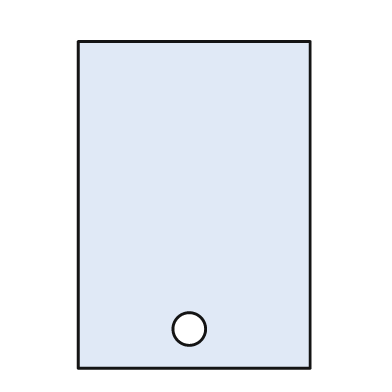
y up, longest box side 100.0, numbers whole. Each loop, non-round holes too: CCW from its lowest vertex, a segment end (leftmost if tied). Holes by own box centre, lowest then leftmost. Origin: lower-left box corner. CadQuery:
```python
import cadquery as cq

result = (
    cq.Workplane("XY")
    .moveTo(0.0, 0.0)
    .lineTo(71.0, 0.0)
    .lineTo(71.0, 100.0)
    .lineTo(0.0, 100.0)
    .close()
    .moveTo(34.0, 12.0)
    .circle(5.0)
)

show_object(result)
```